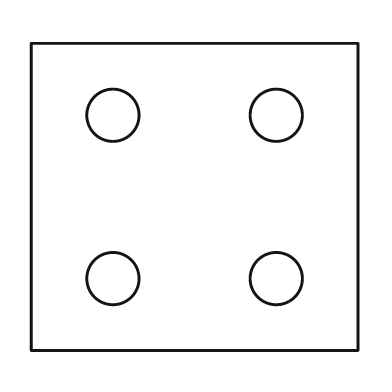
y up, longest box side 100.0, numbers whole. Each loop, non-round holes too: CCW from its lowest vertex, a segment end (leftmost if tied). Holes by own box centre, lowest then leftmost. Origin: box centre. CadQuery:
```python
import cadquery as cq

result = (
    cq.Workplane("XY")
    .moveTo(-50.0, -47.0)
    .lineTo(50.0, -47.0)
    .lineTo(50.0, 47.0)
    .lineTo(-50.0, 47.0)
    .close()
    .moveTo(-25.0, -25.0)
    .circle(8.0)
    .moveTo(25.0, -25.0)
    .circle(8.0)
    .moveTo(-25.0, 25.0)
    .circle(8.0)
    .moveTo(25.0, 25.0)
    .circle(8.0)
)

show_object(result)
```